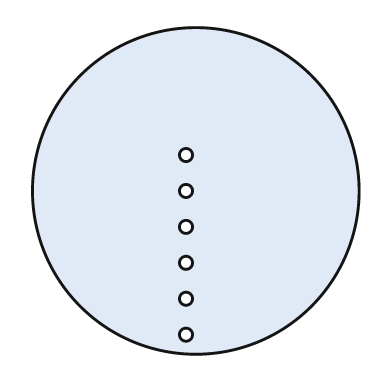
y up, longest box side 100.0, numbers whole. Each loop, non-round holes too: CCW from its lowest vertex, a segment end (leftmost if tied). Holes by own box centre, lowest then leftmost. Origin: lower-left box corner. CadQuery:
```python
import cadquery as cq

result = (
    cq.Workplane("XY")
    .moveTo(50.0, 50.0)
    .circle(50.0)
    .moveTo(47.0, 6.0)
    .circle(2.0)
    .moveTo(47.0, 17.0)
    .circle(2.0)
    .moveTo(47.0, 28.0)
    .circle(2.0)
    .moveTo(47.0, 39.0)
    .circle(2.0)
    .moveTo(47.0, 50.0)
    .circle(2.0)
    .moveTo(47.0, 61.0)
    .circle(2.0)
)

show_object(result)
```